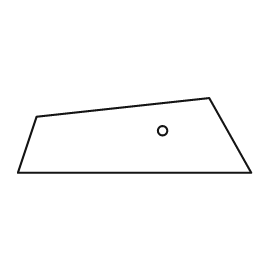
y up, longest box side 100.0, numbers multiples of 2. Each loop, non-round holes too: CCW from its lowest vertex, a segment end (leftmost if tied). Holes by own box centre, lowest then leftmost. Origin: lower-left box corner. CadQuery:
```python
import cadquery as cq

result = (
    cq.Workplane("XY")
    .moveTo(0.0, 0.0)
    .lineTo(100.0, 0.0)
    .lineTo(82.0, 32.0)
    .lineTo(8.0, 24.0)
    .close()
    .moveTo(62.0, 18.0)
    .circle(2.0)
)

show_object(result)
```